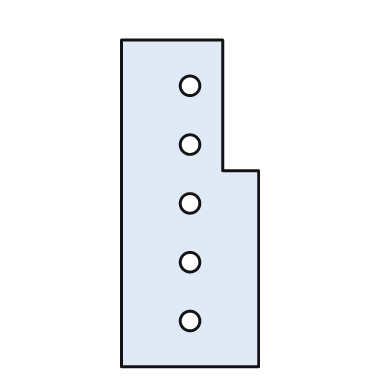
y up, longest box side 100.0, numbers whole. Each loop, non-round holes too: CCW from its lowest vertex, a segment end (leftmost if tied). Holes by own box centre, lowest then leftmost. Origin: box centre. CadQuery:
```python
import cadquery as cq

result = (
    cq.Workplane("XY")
    .moveTo(-21.0, -50.0)
    .lineTo(21.0, -50.0)
    .lineTo(21.0, 10.0)
    .lineTo(10.0, 10.0)
    .lineTo(10.0, 50.0)
    .lineTo(-21.0, 50.0)
    .close()
    .moveTo(0.0, -36.0)
    .circle(3.0)
    .moveTo(0.0, -18.0)
    .circle(3.0)
    .moveTo(0.0, 0.0)
    .circle(3.0)
    .moveTo(0.0, 18.0)
    .circle(3.0)
    .moveTo(0.0, 36.0)
    .circle(3.0)
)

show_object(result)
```